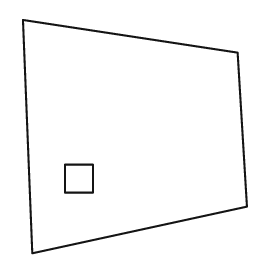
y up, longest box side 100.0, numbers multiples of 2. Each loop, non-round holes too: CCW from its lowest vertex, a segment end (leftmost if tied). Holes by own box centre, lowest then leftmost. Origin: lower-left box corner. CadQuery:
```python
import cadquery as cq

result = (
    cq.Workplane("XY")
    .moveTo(4.0, 0.0)
    .lineTo(96.0, 20.0)
    .lineTo(92.0, 86.0)
    .lineTo(0.0, 100.0)
    .close()
    .moveTo(18.0, 26.0)
    .lineTo(30.0, 26.0)
    .lineTo(30.0, 38.0)
    .lineTo(18.0, 38.0)
    .close()
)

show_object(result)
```